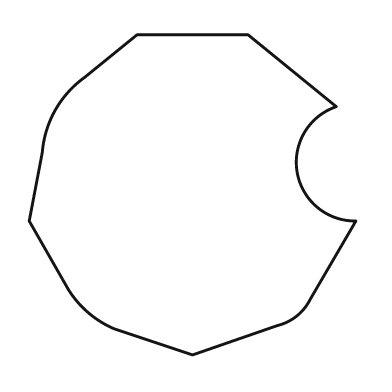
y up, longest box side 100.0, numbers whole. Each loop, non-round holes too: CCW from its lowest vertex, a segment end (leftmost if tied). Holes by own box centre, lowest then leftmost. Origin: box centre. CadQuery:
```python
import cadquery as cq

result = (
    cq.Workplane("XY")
    .moveTo(0.0, -49.0)
    .lineTo(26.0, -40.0)
    .threePointArc((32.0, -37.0), (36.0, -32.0))
    .lineTo(50.0, -8.0)
    .threePointArc((32.0, 7.0), (44.0, 27.0))
    .lineTo(17.0, 49.0)
    .lineTo(-17.0, 49.0)
    .lineTo(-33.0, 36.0)
    .threePointArc((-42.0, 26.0), (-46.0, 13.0))
    .lineTo(-50.0, -8.0)
    .lineTo(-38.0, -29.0)
    .threePointArc((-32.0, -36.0), (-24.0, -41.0))
    .close()
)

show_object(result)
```